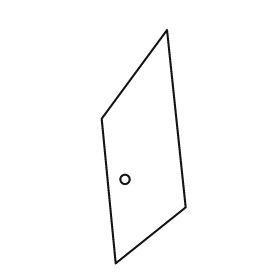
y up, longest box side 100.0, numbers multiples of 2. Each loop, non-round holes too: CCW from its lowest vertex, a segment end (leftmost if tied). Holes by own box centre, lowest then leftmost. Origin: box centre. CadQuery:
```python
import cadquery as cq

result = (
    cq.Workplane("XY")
    .moveTo(-12.0, -50.0)
    .lineTo(18.0, -26.0)
    .lineTo(10.0, 50.0)
    .lineTo(-18.0, 12.0)
    .close()
    .moveTo(-8.0, -14.0)
    .circle(2.0)
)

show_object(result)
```